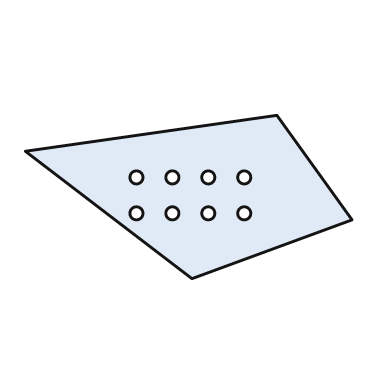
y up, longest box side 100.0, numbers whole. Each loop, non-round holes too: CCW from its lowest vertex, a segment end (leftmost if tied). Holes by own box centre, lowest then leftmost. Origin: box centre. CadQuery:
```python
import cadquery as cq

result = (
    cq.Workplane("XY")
    .moveTo(1.0, -25.0)
    .lineTo(50.0, -7.0)
    .lineTo(27.0, 25.0)
    .lineTo(-50.0, 14.0)
    .close()
    .moveTo(-16.0, -5.0)
    .circle(2.0)
    .moveTo(-5.0, -5.0)
    .circle(2.0)
    .moveTo(6.0, -5.0)
    .circle(2.0)
    .moveTo(17.0, -5.0)
    .circle(2.0)
    .moveTo(-16.0, 6.0)
    .circle(2.0)
    .moveTo(-5.0, 6.0)
    .circle(2.0)
    .moveTo(6.0, 6.0)
    .circle(2.0)
    .moveTo(17.0, 6.0)
    .circle(2.0)
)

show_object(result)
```